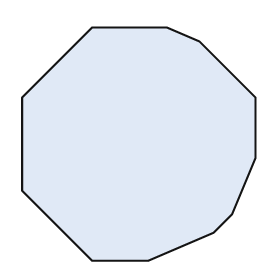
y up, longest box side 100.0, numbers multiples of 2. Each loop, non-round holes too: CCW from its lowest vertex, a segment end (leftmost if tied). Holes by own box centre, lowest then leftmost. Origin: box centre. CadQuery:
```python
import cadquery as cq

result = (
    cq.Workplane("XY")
    .moveTo(-20.0, -50.0)
    .lineTo(4.0, -50.0)
    .lineTo(32.0, -38.0)
    .lineTo(40.0, -30.0)
    .lineTo(50.0, -6.0)
    .lineTo(50.0, 20.0)
    .lineTo(26.0, 44.0)
    .lineTo(12.0, 50.0)
    .lineTo(-20.0, 50.0)
    .lineTo(-50.0, 20.0)
    .lineTo(-50.0, -20.0)
    .close()
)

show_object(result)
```